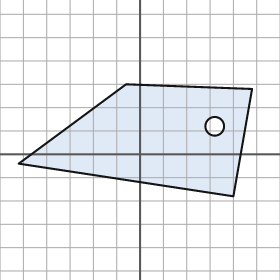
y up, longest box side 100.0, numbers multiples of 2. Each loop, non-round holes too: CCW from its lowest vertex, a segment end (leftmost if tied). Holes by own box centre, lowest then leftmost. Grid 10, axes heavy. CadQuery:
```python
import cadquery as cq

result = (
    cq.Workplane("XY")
    .moveTo(40.0, -18.0)
    .lineTo(48.0, 28.0)
    .lineTo(-6.0, 30.0)
    .lineTo(-52.0, -4.0)
    .close()
    .moveTo(32.0, 12.0)
    .circle(4.0)
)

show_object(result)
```